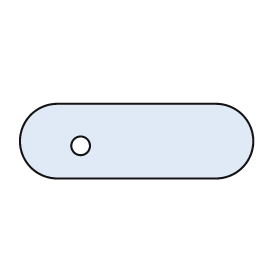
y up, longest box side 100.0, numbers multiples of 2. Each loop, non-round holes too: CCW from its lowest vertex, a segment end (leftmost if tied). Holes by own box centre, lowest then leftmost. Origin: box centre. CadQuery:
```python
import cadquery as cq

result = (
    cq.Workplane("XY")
    .moveTo(-34.0, -16.0)
    .lineTo(34.0, -16.0)
    .threePointArc((50.0, 0.0), (34.0, 16.0))
    .lineTo(-34.0, 16.0)
    .threePointArc((-50.0, 0.0), (-34.0, -16.0))
    .close()
    .moveTo(-24.0, -2.0)
    .circle(4.0)
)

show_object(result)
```